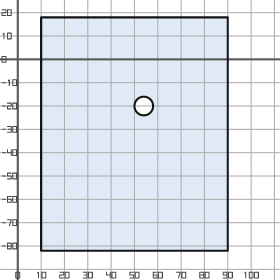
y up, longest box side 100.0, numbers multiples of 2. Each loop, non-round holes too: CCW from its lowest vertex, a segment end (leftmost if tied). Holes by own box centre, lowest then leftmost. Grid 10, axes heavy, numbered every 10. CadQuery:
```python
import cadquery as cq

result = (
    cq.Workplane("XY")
    .moveTo(10.0, -82.0)
    .lineTo(90.0, -82.0)
    .lineTo(90.0, 18.0)
    .lineTo(10.0, 18.0)
    .close()
    .moveTo(54.0, -20.0)
    .circle(4.0)
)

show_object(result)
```